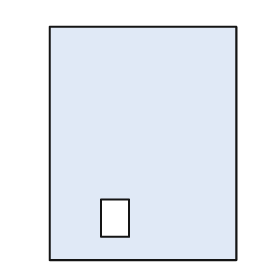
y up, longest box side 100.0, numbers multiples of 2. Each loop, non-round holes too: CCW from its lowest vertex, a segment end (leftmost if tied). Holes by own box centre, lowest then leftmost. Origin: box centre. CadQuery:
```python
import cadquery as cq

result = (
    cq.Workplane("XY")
    .moveTo(-40.0, -50.0)
    .lineTo(40.0, -50.0)
    .lineTo(40.0, 50.0)
    .lineTo(-40.0, 50.0)
    .close()
    .moveTo(-18.0, -40.0)
    .lineTo(-6.0, -40.0)
    .lineTo(-6.0, -24.0)
    .lineTo(-18.0, -24.0)
    .close()
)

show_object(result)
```